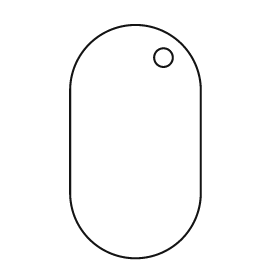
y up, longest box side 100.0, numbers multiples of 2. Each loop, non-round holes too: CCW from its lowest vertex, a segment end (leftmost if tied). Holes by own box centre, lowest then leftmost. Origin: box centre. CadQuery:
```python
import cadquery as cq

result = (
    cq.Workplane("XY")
    .moveTo(-28.0, -22.0)
    .threePointArc((0.0, -50.0), (28.0, -22.0))
    .lineTo(28.0, 22.0)
    .threePointArc((0.0, 50.0), (-28.0, 22.0))
    .close()
    .moveTo(12.0, 36.0)
    .circle(4.0)
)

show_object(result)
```